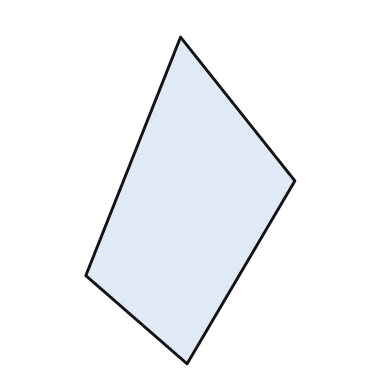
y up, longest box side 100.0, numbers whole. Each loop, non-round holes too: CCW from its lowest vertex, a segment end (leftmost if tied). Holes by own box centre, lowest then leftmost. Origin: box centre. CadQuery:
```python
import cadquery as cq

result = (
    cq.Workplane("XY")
    .moveTo(-1.0, -50.0)
    .lineTo(32.0, 6.0)
    .lineTo(-3.0, 50.0)
    .lineTo(-32.0, -23.0)
    .close()
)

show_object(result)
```